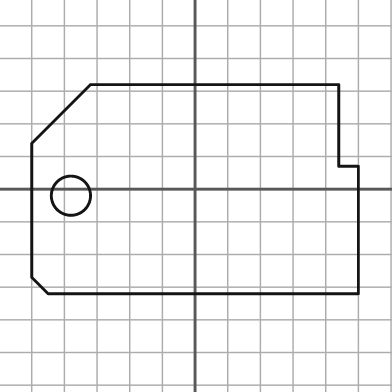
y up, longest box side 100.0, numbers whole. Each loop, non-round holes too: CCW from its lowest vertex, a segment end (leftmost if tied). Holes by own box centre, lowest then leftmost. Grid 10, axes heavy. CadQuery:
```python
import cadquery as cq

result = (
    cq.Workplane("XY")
    .moveTo(-45.0, -32.0)
    .lineTo(50.0, -32.0)
    .lineTo(50.0, 7.0)
    .lineTo(44.0, 7.0)
    .lineTo(44.0, 32.0)
    .lineTo(-32.0, 32.0)
    .lineTo(-50.0, 14.0)
    .lineTo(-50.0, -27.0)
    .close()
    .moveTo(-38.0, -2.0)
    .circle(6.0)
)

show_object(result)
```